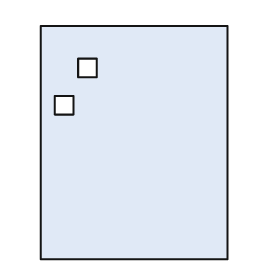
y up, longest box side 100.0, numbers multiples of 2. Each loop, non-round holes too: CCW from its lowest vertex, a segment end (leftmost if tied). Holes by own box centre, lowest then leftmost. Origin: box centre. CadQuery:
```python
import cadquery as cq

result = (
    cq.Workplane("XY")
    .moveTo(-40.0, -50.0)
    .lineTo(40.0, -50.0)
    .lineTo(40.0, 50.0)
    .lineTo(-40.0, 50.0)
    .close()
    .moveTo(-34.0, 12.0)
    .lineTo(-26.0, 12.0)
    .lineTo(-26.0, 20.0)
    .lineTo(-34.0, 20.0)
    .close()
    .moveTo(-24.0, 28.0)
    .lineTo(-16.0, 28.0)
    .lineTo(-16.0, 36.0)
    .lineTo(-24.0, 36.0)
    .close()
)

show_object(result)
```